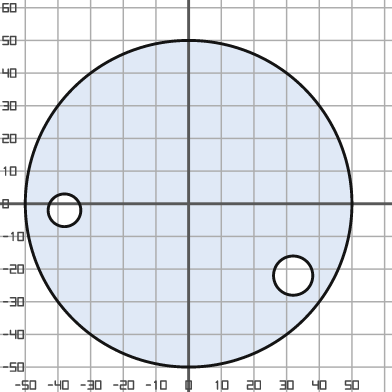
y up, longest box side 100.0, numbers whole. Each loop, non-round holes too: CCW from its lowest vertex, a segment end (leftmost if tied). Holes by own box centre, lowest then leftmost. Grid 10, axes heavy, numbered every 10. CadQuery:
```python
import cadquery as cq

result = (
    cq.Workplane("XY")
    .moveTo(0.0, 0.0)
    .circle(50.0)
    .moveTo(32.0, -22.0)
    .circle(6.0)
    .moveTo(-38.0, -2.0)
    .circle(5.0)
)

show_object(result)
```